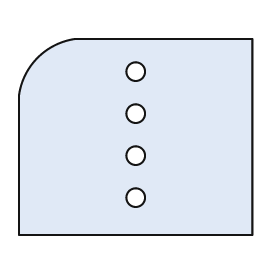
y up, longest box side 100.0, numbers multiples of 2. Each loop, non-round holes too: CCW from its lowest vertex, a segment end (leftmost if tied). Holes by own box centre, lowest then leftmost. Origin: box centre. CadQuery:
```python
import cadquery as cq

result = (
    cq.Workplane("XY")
    .moveTo(-50.0, -42.0)
    .lineTo(50.0, -42.0)
    .lineTo(50.0, 42.0)
    .lineTo(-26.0, 42.0)
    .threePointArc((-42.0, 34.0), (-50.0, 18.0))
    .close()
    .moveTo(0.0, -26.0)
    .circle(4.0)
    .moveTo(0.0, -8.0)
    .circle(4.0)
    .moveTo(0.0, 10.0)
    .circle(4.0)
    .moveTo(0.0, 28.0)
    .circle(4.0)
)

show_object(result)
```